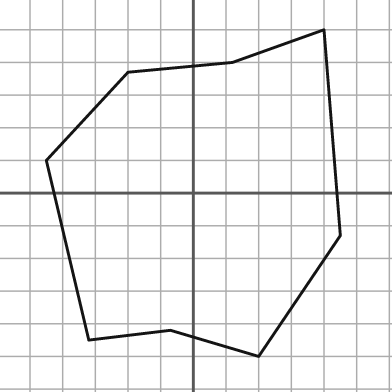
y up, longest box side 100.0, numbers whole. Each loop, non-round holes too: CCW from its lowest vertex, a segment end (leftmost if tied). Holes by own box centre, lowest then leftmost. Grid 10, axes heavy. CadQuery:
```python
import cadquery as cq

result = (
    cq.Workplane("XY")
    .moveTo(20.0, -50.0)
    .lineTo(45.0, -13.0)
    .lineTo(40.0, 50.0)
    .lineTo(12.0, 40.0)
    .lineTo(-20.0, 37.0)
    .lineTo(-45.0, 10.0)
    .lineTo(-32.0, -45.0)
    .lineTo(-7.0, -42.0)
    .close()
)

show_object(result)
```